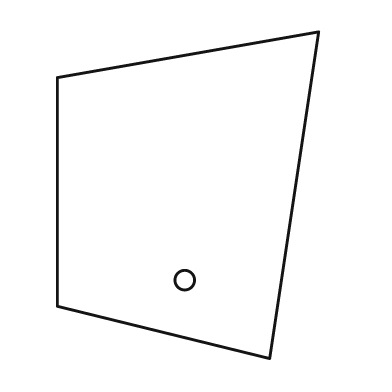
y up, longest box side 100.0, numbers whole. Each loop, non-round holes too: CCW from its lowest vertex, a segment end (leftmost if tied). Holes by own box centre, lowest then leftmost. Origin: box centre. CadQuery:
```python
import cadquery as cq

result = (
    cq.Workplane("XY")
    .moveTo(25.0, -50.0)
    .lineTo(40.0, 50.0)
    .lineTo(-40.0, 36.0)
    .lineTo(-40.0, -34.0)
    .close()
    .moveTo(-1.0, -26.0)
    .circle(3.0)
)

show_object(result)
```